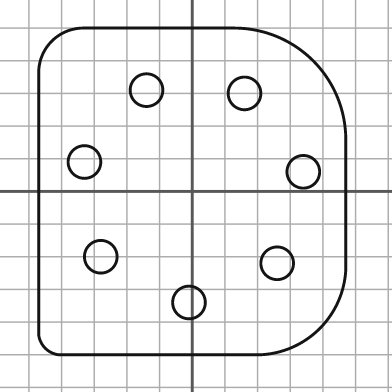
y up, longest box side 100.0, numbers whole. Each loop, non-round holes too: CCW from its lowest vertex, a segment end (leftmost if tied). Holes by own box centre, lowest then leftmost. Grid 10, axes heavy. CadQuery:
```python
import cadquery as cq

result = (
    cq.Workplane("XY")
    .moveTo(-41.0, -50.0)
    .lineTo(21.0, -50.0)
    .threePointArc((39.0, -42.0), (47.0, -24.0))
    .lineTo(47.0, 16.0)
    .threePointArc((37.0, 40.0), (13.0, 50.0))
    .lineTo(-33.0, 50.0)
    .threePointArc((-43.0, 46.0), (-47.0, 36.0))
    .lineTo(-47.0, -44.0)
    .threePointArc((-45.0, -48.0), (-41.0, -50.0))
    .close()
    .moveTo(-1.0, -34.0)
    .circle(5.0)
    .moveTo(26.0, -22.0)
    .circle(5.0)
    .moveTo(-28.0, -20.0)
    .circle(5.0)
    .moveTo(34.0, 6.0)
    .circle(5.0)
    .moveTo(-33.0, 9.0)
    .circle(5.0)
    .moveTo(16.0, 30.0)
    .circle(5.0)
    .moveTo(-14.0, 31.0)
    .circle(5.0)
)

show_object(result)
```